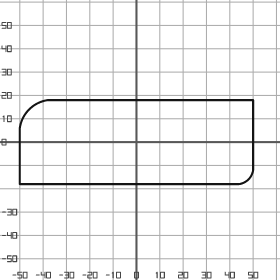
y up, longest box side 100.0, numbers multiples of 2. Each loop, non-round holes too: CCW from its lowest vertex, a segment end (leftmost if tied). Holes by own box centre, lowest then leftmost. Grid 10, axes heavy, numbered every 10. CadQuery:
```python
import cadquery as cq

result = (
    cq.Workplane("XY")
    .moveTo(-50.0, -18.0)
    .lineTo(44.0, -18.0)
    .threePointArc((48.0, -16.0), (50.0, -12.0))
    .lineTo(50.0, 18.0)
    .lineTo(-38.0, 18.0)
    .threePointArc((-46.0, 14.0), (-50.0, 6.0))
    .close()
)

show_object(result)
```